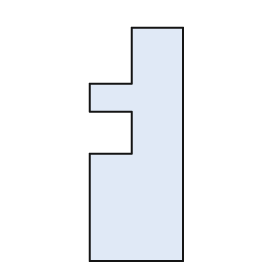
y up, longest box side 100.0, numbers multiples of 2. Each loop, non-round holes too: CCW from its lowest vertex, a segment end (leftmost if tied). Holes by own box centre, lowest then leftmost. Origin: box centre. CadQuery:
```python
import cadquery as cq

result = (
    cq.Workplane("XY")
    .moveTo(-20.0, -50.0)
    .lineTo(20.0, -50.0)
    .lineTo(20.0, 50.0)
    .lineTo(-2.0, 50.0)
    .lineTo(-2.0, 26.0)
    .lineTo(-20.0, 26.0)
    .lineTo(-20.0, 14.0)
    .lineTo(-2.0, 14.0)
    .lineTo(-2.0, -4.0)
    .lineTo(-20.0, -4.0)
    .close()
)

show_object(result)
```